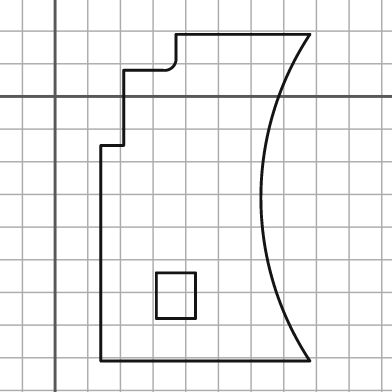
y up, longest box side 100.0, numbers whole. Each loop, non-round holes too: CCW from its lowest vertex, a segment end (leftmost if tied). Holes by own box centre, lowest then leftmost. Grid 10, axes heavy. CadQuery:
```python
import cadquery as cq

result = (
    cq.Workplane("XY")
    .moveTo(14.0, -81.0)
    .lineTo(78.0, -81.0)
    .threePointArc((63.0, -31.0), (78.0, 19.0))
    .lineTo(37.0, 19.0)
    .lineTo(37.0, 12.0)
    .threePointArc((36.0, 9.0), (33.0, 8.0))
    .lineTo(21.0, 8.0)
    .lineTo(21.0, -15.0)
    .lineTo(14.0, -15.0)
    .close()
    .moveTo(31.0, -68.0)
    .lineTo(43.0, -68.0)
    .lineTo(43.0, -54.0)
    .lineTo(31.0, -54.0)
    .close()
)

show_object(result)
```